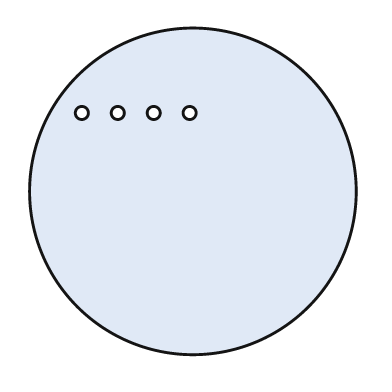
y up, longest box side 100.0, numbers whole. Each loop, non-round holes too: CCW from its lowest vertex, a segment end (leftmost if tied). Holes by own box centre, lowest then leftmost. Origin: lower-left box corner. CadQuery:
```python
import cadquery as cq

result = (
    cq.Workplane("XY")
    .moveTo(50.0, 50.0)
    .circle(50.0)
    .moveTo(16.0, 74.0)
    .circle(2.0)
    .moveTo(27.0, 74.0)
    .circle(2.0)
    .moveTo(38.0, 74.0)
    .circle(2.0)
    .moveTo(49.0, 74.0)
    .circle(2.0)
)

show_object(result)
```